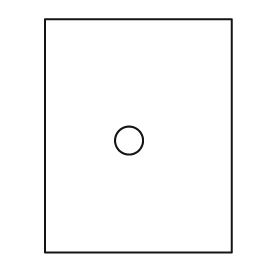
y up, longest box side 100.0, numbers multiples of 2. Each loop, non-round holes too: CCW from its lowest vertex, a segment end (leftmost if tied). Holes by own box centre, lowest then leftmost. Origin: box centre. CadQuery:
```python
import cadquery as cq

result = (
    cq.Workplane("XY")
    .moveTo(-40.0, -50.0)
    .lineTo(40.0, -50.0)
    .lineTo(40.0, 50.0)
    .lineTo(-40.0, 50.0)
    .close()
    .moveTo(-4.0, -2.0)
    .circle(6.0)
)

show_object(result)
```